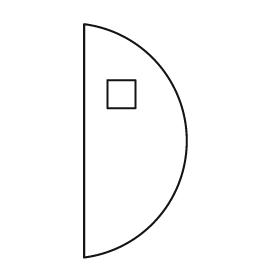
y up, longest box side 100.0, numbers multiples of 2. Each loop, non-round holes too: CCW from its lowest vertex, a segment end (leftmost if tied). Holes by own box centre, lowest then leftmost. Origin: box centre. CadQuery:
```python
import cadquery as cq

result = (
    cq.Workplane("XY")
    .moveTo(-22.0, -50.0)
    .threePointArc((22.0, 0.0), (-22.0, 50.0))
    .close()
    .moveTo(-12.0, 14.0)
    .lineTo(0.0, 14.0)
    .lineTo(0.0, 26.0)
    .lineTo(-12.0, 26.0)
    .close()
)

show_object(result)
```